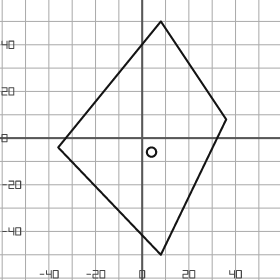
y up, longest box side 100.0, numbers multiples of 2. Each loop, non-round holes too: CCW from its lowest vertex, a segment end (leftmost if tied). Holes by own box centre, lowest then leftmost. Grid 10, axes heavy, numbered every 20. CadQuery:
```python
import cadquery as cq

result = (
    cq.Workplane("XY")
    .moveTo(8.0, -50.0)
    .lineTo(36.0, 8.0)
    .lineTo(8.0, 50.0)
    .lineTo(-36.0, -4.0)
    .close()
    .moveTo(4.0, -6.0)
    .circle(2.0)
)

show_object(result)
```